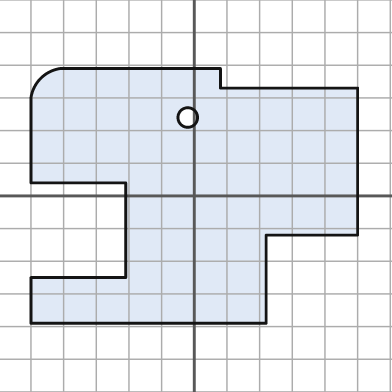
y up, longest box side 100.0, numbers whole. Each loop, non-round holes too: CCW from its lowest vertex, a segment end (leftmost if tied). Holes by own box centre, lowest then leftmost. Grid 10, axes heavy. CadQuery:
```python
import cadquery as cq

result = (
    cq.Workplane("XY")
    .moveTo(-50.0, -39.0)
    .lineTo(22.0, -39.0)
    .lineTo(22.0, -12.0)
    .lineTo(50.0, -12.0)
    .lineTo(50.0, 33.0)
    .lineTo(8.0, 33.0)
    .lineTo(8.0, 39.0)
    .lineTo(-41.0, 39.0)
    .threePointArc((-47.0, 36.0), (-50.0, 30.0))
    .lineTo(-50.0, 4.0)
    .lineTo(-21.0, 4.0)
    .lineTo(-21.0, -25.0)
    .lineTo(-50.0, -25.0)
    .close()
    .moveTo(-2.0, 24.0)
    .circle(3.0)
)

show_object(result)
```